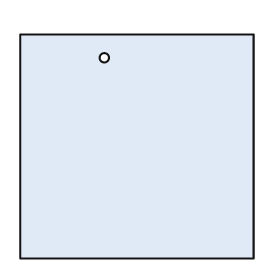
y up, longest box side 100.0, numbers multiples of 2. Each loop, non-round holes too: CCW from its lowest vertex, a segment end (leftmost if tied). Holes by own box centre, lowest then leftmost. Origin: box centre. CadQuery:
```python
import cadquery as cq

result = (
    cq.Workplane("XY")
    .moveTo(-50.0, -48.0)
    .lineTo(50.0, -48.0)
    .lineTo(50.0, 48.0)
    .lineTo(-50.0, 48.0)
    .close()
    .moveTo(-14.0, 38.0)
    .circle(2.0)
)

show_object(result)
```